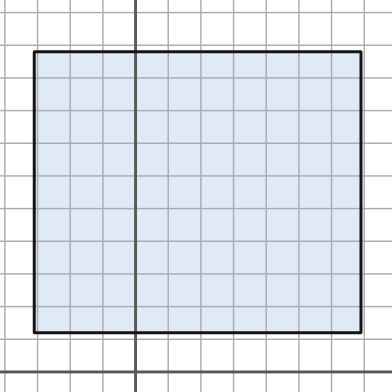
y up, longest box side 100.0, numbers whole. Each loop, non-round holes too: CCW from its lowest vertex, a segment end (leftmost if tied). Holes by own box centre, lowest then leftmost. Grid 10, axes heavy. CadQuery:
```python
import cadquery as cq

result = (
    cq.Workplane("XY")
    .moveTo(-31.0, 12.0)
    .lineTo(69.0, 12.0)
    .lineTo(69.0, 98.0)
    .lineTo(-31.0, 98.0)
    .close()
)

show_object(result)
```